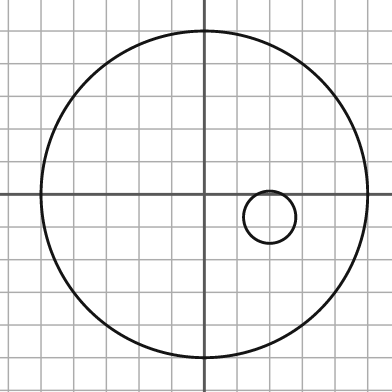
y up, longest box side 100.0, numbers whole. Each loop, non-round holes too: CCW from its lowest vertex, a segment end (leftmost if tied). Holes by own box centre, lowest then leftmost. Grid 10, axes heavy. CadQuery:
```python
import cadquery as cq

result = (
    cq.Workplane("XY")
    .moveTo(0.0, 0.0)
    .circle(50.0)
    .moveTo(20.0, -7.0)
    .circle(8.0)
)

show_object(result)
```